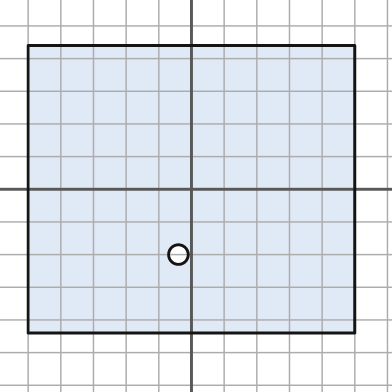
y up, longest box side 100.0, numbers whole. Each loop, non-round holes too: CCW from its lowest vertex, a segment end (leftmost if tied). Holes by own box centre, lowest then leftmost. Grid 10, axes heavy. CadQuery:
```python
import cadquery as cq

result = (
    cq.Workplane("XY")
    .moveTo(-50.0, -44.0)
    .lineTo(50.0, -44.0)
    .lineTo(50.0, 44.0)
    .lineTo(-50.0, 44.0)
    .close()
    .moveTo(-4.0, -20.0)
    .circle(3.0)
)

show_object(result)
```